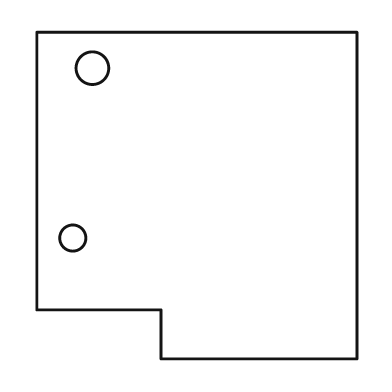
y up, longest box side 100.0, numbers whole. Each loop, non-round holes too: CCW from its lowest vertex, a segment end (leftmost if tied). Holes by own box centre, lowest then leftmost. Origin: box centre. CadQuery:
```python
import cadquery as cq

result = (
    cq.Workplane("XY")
    .moveTo(-11.0, -50.0)
    .lineTo(49.0, -50.0)
    .lineTo(49.0, 50.0)
    .lineTo(-49.0, 50.0)
    .lineTo(-49.0, -35.0)
    .lineTo(-11.0, -35.0)
    .close()
    .moveTo(-38.0, -13.0)
    .circle(4.0)
    .moveTo(-32.0, 39.0)
    .circle(5.0)
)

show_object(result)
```